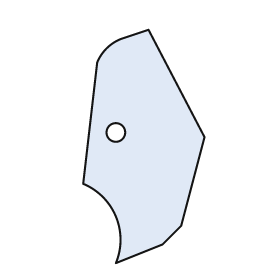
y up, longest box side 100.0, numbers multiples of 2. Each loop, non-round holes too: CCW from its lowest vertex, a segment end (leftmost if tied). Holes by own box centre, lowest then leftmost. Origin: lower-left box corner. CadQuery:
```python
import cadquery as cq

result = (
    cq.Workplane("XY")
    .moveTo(14.0, 0.0)
    .lineTo(34.0, 8.0)
    .lineTo(42.0, 16.0)
    .lineTo(52.0, 54.0)
    .lineTo(28.0, 100.0)
    .lineTo(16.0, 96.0)
    .threePointArc((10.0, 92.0), (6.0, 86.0))
    .lineTo(0.0, 34.0)
    .threePointArc((14.0, 20.0), (14.0, 0.0))
    .close()
    .moveTo(14.0, 56.0)
    .circle(4.0)
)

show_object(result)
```